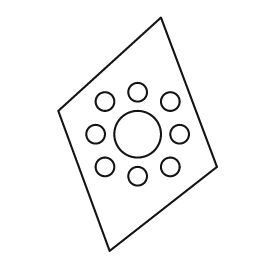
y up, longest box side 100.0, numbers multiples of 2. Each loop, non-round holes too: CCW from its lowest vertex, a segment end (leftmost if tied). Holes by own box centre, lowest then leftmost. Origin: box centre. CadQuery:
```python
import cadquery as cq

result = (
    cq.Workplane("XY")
    .moveTo(-12.0, -50.0)
    .lineTo(34.0, -14.0)
    .lineTo(10.0, 50.0)
    .lineTo(-34.0, 10.0)
    .close()
    .moveTo(0.0, -18.0)
    .circle(4.0)
    .moveTo(-14.0, -14.0)
    .circle(4.0)
    .moveTo(14.0, -14.0)
    .circle(4.0)
    .moveTo(-18.0, 0.0)
    .circle(4.0)
    .moveTo(0.0, 0.0)
    .circle(10.0)
    .moveTo(18.0, 0.0)
    .circle(4.0)
    .moveTo(-14.0, 14.0)
    .circle(4.0)
    .moveTo(14.0, 14.0)
    .circle(4.0)
    .moveTo(0.0, 18.0)
    .circle(4.0)
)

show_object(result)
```